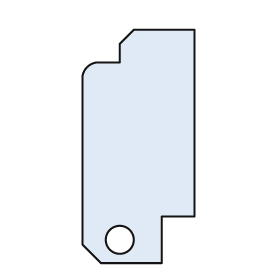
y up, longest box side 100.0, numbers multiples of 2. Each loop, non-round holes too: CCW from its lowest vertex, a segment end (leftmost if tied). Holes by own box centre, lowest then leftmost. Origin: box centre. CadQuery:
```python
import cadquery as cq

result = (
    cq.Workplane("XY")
    .moveTo(-16.0, -50.0)
    .lineTo(10.0, -50.0)
    .lineTo(10.0, -30.0)
    .lineTo(24.0, -30.0)
    .lineTo(24.0, 50.0)
    .lineTo(-2.0, 50.0)
    .lineTo(-8.0, 44.0)
    .lineTo(-8.0, 36.0)
    .lineTo(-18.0, 36.0)
    .threePointArc((-22.0, 34.0), (-24.0, 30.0))
    .lineTo(-24.0, -42.0)
    .close()
    .moveTo(-8.0, -40.0)
    .circle(6.0)
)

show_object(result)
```